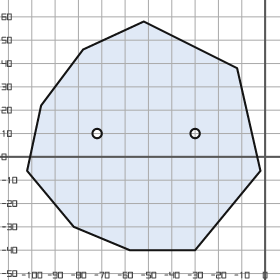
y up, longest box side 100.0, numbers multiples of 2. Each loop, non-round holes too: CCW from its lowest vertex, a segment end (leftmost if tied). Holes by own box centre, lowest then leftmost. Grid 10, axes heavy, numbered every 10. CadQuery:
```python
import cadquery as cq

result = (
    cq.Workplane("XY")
    .moveTo(-58.0, -40.0)
    .lineTo(-30.0, -40.0)
    .lineTo(-2.0, -6.0)
    .lineTo(-12.0, 38.0)
    .lineTo(-52.0, 58.0)
    .lineTo(-78.0, 46.0)
    .lineTo(-96.0, 22.0)
    .lineTo(-102.0, -6.0)
    .lineTo(-82.0, -30.0)
    .close()
    .moveTo(-72.0, 10.0)
    .circle(2.0)
    .moveTo(-30.0, 10.0)
    .circle(2.0)
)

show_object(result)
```